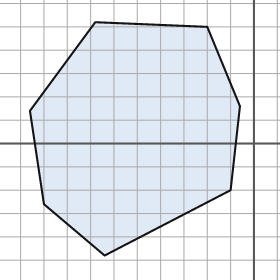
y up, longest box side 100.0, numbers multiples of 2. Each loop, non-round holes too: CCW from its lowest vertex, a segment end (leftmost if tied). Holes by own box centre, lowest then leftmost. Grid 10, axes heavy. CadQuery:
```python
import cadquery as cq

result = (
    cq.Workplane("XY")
    .moveTo(-64.0, -48.0)
    .lineTo(-10.0, -20.0)
    .lineTo(-6.0, 16.0)
    .lineTo(-20.0, 50.0)
    .lineTo(-68.0, 52.0)
    .lineTo(-96.0, 14.0)
    .lineTo(-90.0, -26.0)
    .close()
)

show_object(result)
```